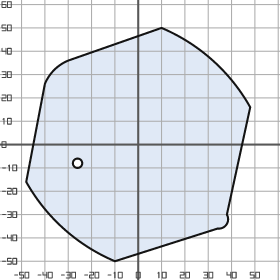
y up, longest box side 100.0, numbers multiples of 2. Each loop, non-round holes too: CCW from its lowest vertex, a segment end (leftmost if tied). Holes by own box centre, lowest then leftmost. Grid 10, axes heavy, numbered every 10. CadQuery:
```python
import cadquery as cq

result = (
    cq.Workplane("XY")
    .moveTo(-10.0, -50.0)
    .lineTo(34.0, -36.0)
    .threePointArc((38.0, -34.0), (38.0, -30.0))
    .lineTo(48.0, 16.0)
    .threePointArc((32.0, 36.0), (10.0, 50.0))
    .lineTo(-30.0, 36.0)
    .threePointArc((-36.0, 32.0), (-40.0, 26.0))
    .lineTo(-48.0, -16.0)
    .threePointArc((-32.0, -36.0), (-10.0, -50.0))
    .close()
    .moveTo(-26.0, -8.0)
    .circle(2.0)
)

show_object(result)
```